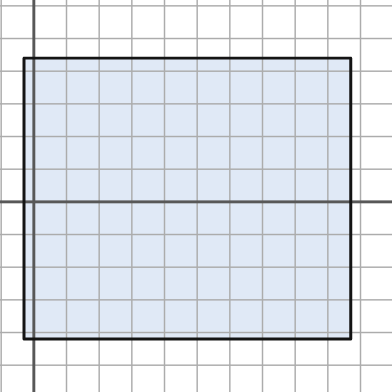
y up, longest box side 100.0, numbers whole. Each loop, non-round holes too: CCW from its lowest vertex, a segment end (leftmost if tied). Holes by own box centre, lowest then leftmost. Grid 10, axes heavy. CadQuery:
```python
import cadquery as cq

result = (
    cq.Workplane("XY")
    .moveTo(-3.0, -42.0)
    .lineTo(97.0, -42.0)
    .lineTo(97.0, 44.0)
    .lineTo(-3.0, 44.0)
    .close()
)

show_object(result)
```